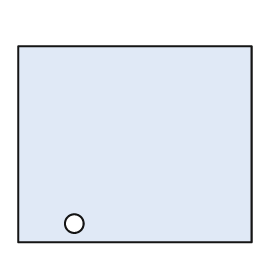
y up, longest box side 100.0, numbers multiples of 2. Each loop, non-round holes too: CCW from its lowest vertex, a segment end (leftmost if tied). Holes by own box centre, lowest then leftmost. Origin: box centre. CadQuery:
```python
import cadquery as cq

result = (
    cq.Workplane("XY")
    .moveTo(-50.0, -42.0)
    .lineTo(50.0, -42.0)
    .lineTo(50.0, 42.0)
    .lineTo(-50.0, 42.0)
    .close()
    .moveTo(-26.0, -34.0)
    .circle(4.0)
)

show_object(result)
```